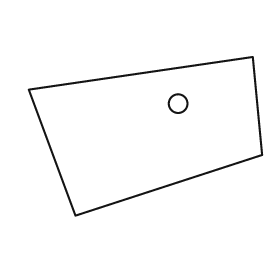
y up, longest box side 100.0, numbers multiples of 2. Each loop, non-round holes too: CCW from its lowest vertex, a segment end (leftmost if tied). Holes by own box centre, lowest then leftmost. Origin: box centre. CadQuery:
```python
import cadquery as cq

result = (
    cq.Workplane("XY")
    .moveTo(-30.0, -34.0)
    .lineTo(50.0, -8.0)
    .lineTo(46.0, 34.0)
    .lineTo(-50.0, 20.0)
    .close()
    .moveTo(14.0, 14.0)
    .circle(4.0)
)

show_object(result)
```